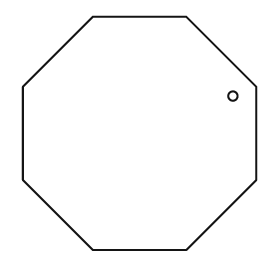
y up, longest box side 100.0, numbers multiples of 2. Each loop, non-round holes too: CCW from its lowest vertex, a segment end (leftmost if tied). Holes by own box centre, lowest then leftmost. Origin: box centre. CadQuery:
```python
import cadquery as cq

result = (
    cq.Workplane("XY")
    .moveTo(-20.0, -50.0)
    .lineTo(20.0, -50.0)
    .lineTo(50.0, -20.0)
    .lineTo(50.0, 20.0)
    .lineTo(20.0, 50.0)
    .lineTo(-20.0, 50.0)
    .lineTo(-50.0, 20.0)
    .lineTo(-50.0, -20.0)
    .close()
    .moveTo(40.0, 16.0)
    .circle(2.0)
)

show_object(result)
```